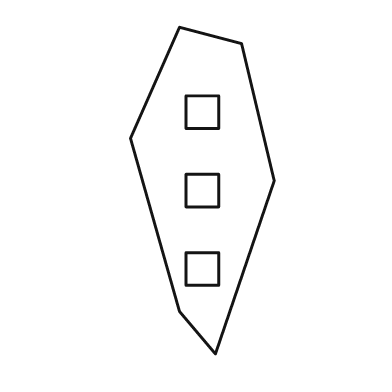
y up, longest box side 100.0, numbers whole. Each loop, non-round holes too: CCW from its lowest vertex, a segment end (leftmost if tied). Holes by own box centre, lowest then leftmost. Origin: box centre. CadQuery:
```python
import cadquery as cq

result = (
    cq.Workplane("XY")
    .moveTo(4.0, -50.0)
    .lineTo(22.0, 3.0)
    .lineTo(12.0, 45.0)
    .lineTo(-7.0, 50.0)
    .lineTo(-22.0, 16.0)
    .lineTo(-7.0, -37.0)
    .close()
    .moveTo(-5.0, -29.0)
    .lineTo(5.0, -29.0)
    .lineTo(5.0, -19.0)
    .lineTo(-5.0, -19.0)
    .close()
    .moveTo(-5.0, -5.0)
    .lineTo(5.0, -5.0)
    .lineTo(5.0, 5.0)
    .lineTo(-5.0, 5.0)
    .close()
    .moveTo(-5.0, 19.0)
    .lineTo(5.0, 19.0)
    .lineTo(5.0, 29.0)
    .lineTo(-5.0, 29.0)
    .close()
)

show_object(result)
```